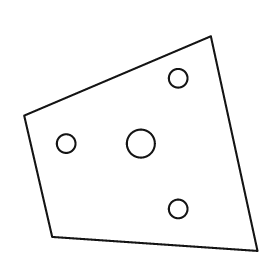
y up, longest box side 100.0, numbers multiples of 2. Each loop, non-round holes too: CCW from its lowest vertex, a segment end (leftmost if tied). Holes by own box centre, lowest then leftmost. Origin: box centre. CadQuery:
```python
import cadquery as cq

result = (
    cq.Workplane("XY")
    .moveTo(50.0, -46.0)
    .lineTo(30.0, 46.0)
    .lineTo(-50.0, 12.0)
    .lineTo(-38.0, -40.0)
    .close()
    .moveTo(16.0, -28.0)
    .circle(4.0)
    .moveTo(-32.0, 0.0)
    .circle(4.0)
    .moveTo(0.0, 0.0)
    .circle(6.0)
    .moveTo(16.0, 28.0)
    .circle(4.0)
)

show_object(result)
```